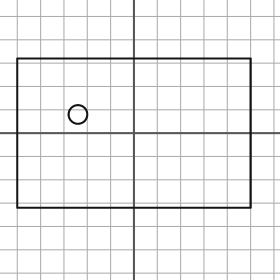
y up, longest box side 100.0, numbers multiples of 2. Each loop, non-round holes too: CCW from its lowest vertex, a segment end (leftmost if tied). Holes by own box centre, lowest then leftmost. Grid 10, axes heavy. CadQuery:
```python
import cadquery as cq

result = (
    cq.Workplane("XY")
    .moveTo(-50.0, -32.0)
    .lineTo(50.0, -32.0)
    .lineTo(50.0, 32.0)
    .lineTo(-50.0, 32.0)
    .close()
    .moveTo(-24.0, 8.0)
    .circle(4.0)
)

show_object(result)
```